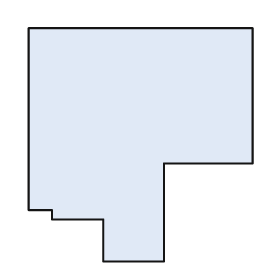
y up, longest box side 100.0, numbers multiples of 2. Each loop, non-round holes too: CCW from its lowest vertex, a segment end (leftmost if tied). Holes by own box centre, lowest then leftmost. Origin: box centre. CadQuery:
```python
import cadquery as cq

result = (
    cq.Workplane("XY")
    .moveTo(-16.0, -50.0)
    .lineTo(10.0, -50.0)
    .lineTo(10.0, -8.0)
    .lineTo(48.0, -8.0)
    .lineTo(48.0, 50.0)
    .lineTo(-48.0, 50.0)
    .lineTo(-48.0, -28.0)
    .lineTo(-38.0, -28.0)
    .lineTo(-38.0, -32.0)
    .lineTo(-16.0, -32.0)
    .close()
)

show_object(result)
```